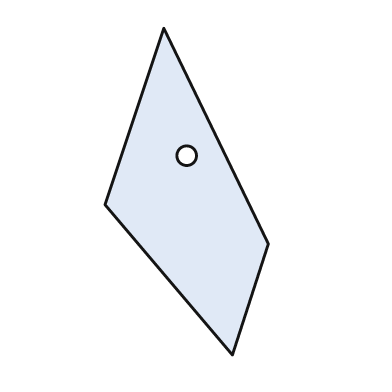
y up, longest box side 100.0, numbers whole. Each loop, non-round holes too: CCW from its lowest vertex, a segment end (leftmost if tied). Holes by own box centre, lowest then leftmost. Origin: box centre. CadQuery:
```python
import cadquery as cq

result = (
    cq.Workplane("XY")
    .moveTo(14.0, -50.0)
    .lineTo(25.0, -16.0)
    .lineTo(-7.0, 50.0)
    .lineTo(-25.0, -4.0)
    .close()
    .moveTo(0.0, 11.0)
    .circle(3.0)
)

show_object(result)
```